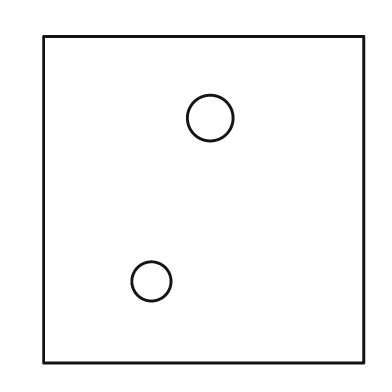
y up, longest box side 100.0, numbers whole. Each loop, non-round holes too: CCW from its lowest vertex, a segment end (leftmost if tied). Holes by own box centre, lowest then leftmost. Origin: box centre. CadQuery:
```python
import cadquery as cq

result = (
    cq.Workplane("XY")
    .moveTo(-49.0, -50.0)
    .lineTo(49.0, -50.0)
    .lineTo(49.0, 50.0)
    .lineTo(-49.0, 50.0)
    .close()
    .moveTo(-16.0, -25.0)
    .circle(6.0)
    .moveTo(2.0, 25.0)
    .circle(7.0)
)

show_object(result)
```